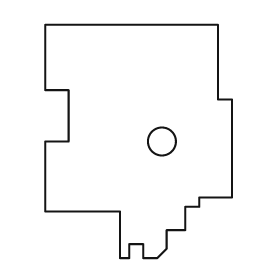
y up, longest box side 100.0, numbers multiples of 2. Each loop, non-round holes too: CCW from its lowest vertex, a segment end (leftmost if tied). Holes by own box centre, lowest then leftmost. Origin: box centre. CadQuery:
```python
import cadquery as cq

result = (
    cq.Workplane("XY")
    .moveTo(-8.0, -50.0)
    .lineTo(-4.0, -50.0)
    .lineTo(-4.0, -44.0)
    .lineTo(2.0, -44.0)
    .lineTo(2.0, -50.0)
    .lineTo(8.0, -50.0)
    .lineTo(12.0, -46.0)
    .lineTo(12.0, -38.0)
    .lineTo(20.0, -38.0)
    .lineTo(20.0, -28.0)
    .lineTo(26.0, -28.0)
    .lineTo(26.0, -24.0)
    .lineTo(40.0, -24.0)
    .lineTo(40.0, 18.0)
    .lineTo(34.0, 18.0)
    .lineTo(34.0, 50.0)
    .lineTo(-40.0, 50.0)
    .lineTo(-40.0, 22.0)
    .lineTo(-30.0, 22.0)
    .lineTo(-30.0, 0.0)
    .lineTo(-40.0, 0.0)
    .lineTo(-40.0, -30.0)
    .lineTo(-8.0, -30.0)
    .close()
    .moveTo(10.0, 0.0)
    .circle(6.0)
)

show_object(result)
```